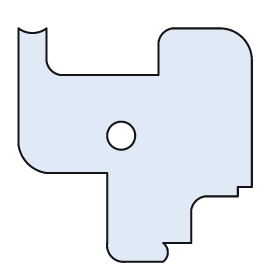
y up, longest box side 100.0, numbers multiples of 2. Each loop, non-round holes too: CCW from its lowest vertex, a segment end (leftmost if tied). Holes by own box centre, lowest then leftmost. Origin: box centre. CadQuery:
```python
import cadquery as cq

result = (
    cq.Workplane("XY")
    .moveTo(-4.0, -50.0)
    .lineTo(12.0, -50.0)
    .threePointArc((14.0, -46.0), (12.0, -42.0))
    .lineTo(24.0, -42.0)
    .lineTo(24.0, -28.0)
    .threePointArc((26.0, -24.0), (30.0, -22.0))
    .lineTo(44.0, -22.0)
    .lineTo(44.0, -18.0)
    .lineTo(50.0, -18.0)
    .lineTo(50.0, 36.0)
    .threePointArc((46.0, 46.0), (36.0, 50.0))
    .lineTo(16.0, 50.0)
    .threePointArc((12.0, 48.0), (10.0, 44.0))
    .lineTo(10.0, 30.0)
    .lineTo(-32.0, 30.0)
    .threePointArc((-36.0, 32.0), (-38.0, 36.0))
    .lineTo(-38.0, 50.0)
    .threePointArc((-44.0, 48.0), (-50.0, 50.0))
    .lineTo(-50.0, 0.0)
    .threePointArc((-46.0, -8.0), (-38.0, -12.0))
    .lineTo(-12.0, -12.0)
    .lineTo(-12.0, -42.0)
    .threePointArc((-10.0, -48.0), (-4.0, -50.0))
    .close()
    .moveTo(-6.0, 4.0)
    .circle(6.0)
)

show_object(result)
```